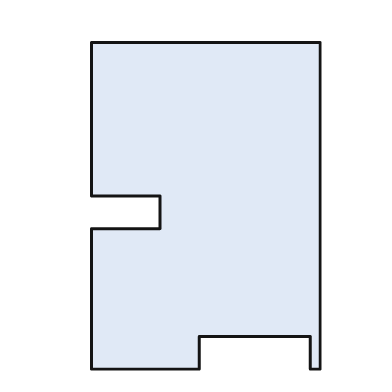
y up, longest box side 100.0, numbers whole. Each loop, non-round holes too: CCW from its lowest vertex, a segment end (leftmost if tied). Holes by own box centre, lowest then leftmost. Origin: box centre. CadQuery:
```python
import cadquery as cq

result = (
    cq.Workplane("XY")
    .moveTo(-35.0, -50.0)
    .lineTo(-2.0, -50.0)
    .lineTo(-2.0, -40.0)
    .lineTo(32.0, -40.0)
    .lineTo(32.0, -50.0)
    .lineTo(35.0, -50.0)
    .lineTo(35.0, 50.0)
    .lineTo(-35.0, 50.0)
    .lineTo(-35.0, 3.0)
    .lineTo(-14.0, 3.0)
    .lineTo(-14.0, -7.0)
    .lineTo(-35.0, -7.0)
    .close()
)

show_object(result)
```